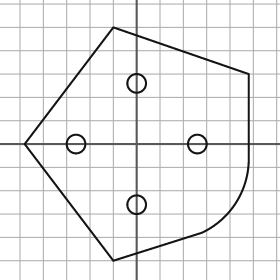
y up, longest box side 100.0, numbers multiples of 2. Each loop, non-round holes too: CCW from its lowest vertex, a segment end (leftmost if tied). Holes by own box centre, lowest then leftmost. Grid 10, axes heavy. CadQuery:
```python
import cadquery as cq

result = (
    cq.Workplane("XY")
    .moveTo(-10.0, -50.0)
    .lineTo(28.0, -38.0)
    .threePointArc((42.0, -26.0), (48.0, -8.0))
    .lineTo(48.0, 30.0)
    .lineTo(-10.0, 50.0)
    .lineTo(-48.0, 0.0)
    .close()
    .moveTo(0.0, -26.0)
    .circle(4.0)
    .moveTo(-26.0, 0.0)
    .circle(4.0)
    .moveTo(26.0, 0.0)
    .circle(4.0)
    .moveTo(0.0, 26.0)
    .circle(4.0)
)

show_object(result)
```